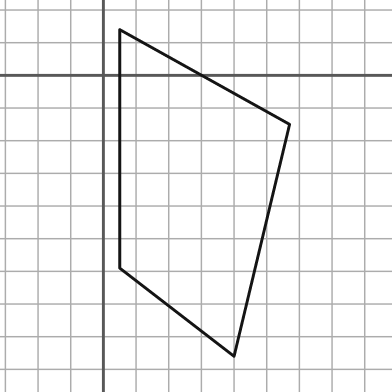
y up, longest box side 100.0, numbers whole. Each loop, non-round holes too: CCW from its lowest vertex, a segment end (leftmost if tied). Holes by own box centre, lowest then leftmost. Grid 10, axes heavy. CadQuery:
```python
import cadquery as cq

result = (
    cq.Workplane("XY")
    .moveTo(40.0, -86.0)
    .lineTo(57.0, -15.0)
    .lineTo(5.0, 14.0)
    .lineTo(5.0, -59.0)
    .close()
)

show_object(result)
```